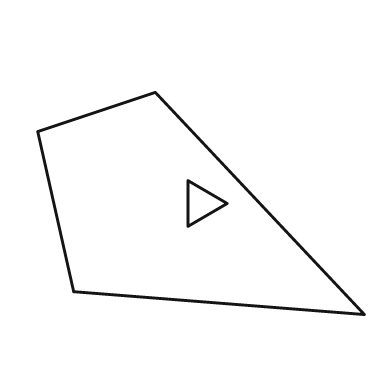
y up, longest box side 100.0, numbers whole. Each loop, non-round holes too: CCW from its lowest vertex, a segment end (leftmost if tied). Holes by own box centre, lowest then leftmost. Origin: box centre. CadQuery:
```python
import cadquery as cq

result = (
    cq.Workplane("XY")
    .moveTo(50.0, -34.0)
    .lineTo(-14.0, 34.0)
    .lineTo(-50.0, 22.0)
    .lineTo(-39.0, -27.0)
    .close()
    .moveTo(-4.0, -7.0)
    .lineTo(8.0, 0.0)
    .lineTo(-4.0, 7.0)
    .close()
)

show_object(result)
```